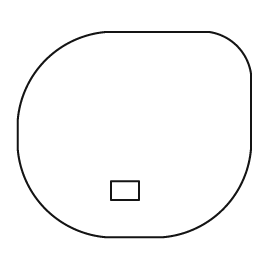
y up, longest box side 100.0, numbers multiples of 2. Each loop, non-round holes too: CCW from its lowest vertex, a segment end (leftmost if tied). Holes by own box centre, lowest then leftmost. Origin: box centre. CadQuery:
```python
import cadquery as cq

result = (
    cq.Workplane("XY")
    .moveTo(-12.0, -44.0)
    .lineTo(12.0, -44.0)
    .threePointArc((38.0, -32.0), (50.0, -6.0))
    .lineTo(50.0, 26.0)
    .threePointArc((44.0, 38.0), (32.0, 44.0))
    .lineTo(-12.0, 44.0)
    .threePointArc((-38.0, 32.0), (-50.0, 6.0))
    .lineTo(-50.0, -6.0)
    .threePointArc((-38.0, -32.0), (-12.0, -44.0))
    .close()
    .moveTo(-10.0, -28.0)
    .lineTo(2.0, -28.0)
    .lineTo(2.0, -20.0)
    .lineTo(-10.0, -20.0)
    .close()
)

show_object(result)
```